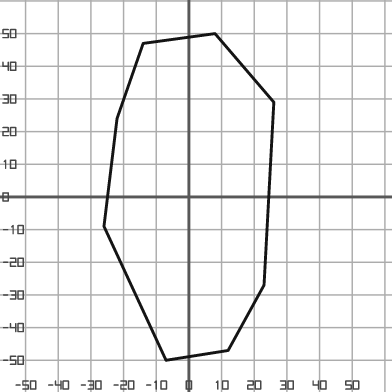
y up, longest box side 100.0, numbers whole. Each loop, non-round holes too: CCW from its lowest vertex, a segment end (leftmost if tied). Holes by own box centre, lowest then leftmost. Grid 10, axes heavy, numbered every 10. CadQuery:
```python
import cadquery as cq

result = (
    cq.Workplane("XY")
    .moveTo(-7.0, -50.0)
    .lineTo(12.0, -47.0)
    .lineTo(23.0, -27.0)
    .lineTo(26.0, 29.0)
    .lineTo(8.0, 50.0)
    .lineTo(-14.0, 47.0)
    .lineTo(-22.0, 24.0)
    .lineTo(-26.0, -9.0)
    .close()
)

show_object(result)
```